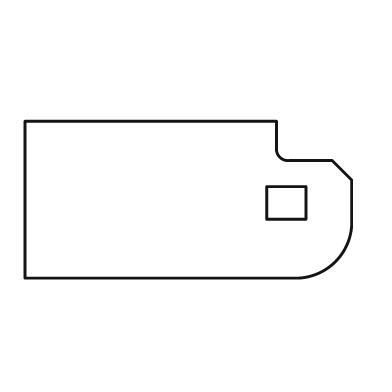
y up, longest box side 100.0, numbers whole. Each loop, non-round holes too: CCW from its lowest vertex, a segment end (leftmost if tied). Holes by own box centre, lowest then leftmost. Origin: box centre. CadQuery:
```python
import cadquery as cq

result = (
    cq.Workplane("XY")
    .moveTo(-50.0, -24.0)
    .lineTo(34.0, -24.0)
    .threePointArc((45.0, -19.0), (50.0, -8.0))
    .lineTo(50.0, 6.0)
    .lineTo(44.0, 12.0)
    .lineTo(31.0, 12.0)
    .threePointArc((28.0, 13.0), (27.0, 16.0))
    .lineTo(27.0, 24.0)
    .lineTo(-50.0, 24.0)
    .close()
    .moveTo(24.0, -6.0)
    .lineTo(36.0, -6.0)
    .lineTo(36.0, 4.0)
    .lineTo(24.0, 4.0)
    .close()
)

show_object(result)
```